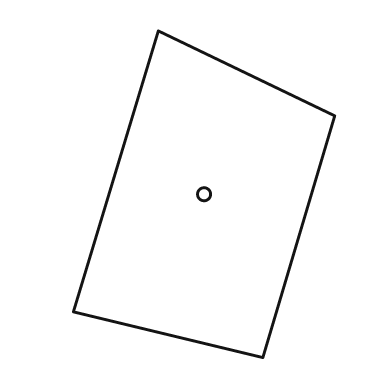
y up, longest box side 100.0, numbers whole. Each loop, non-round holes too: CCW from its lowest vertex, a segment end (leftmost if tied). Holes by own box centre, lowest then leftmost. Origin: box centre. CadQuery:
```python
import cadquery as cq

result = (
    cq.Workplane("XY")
    .moveTo(18.0, -50.0)
    .lineTo(40.0, 24.0)
    .lineTo(-14.0, 50.0)
    .lineTo(-40.0, -36.0)
    .close()
    .moveTo(0.0, 0.0)
    .circle(2.0)
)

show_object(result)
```